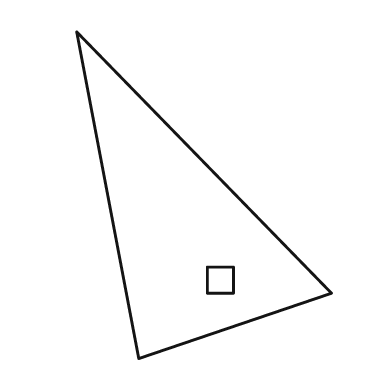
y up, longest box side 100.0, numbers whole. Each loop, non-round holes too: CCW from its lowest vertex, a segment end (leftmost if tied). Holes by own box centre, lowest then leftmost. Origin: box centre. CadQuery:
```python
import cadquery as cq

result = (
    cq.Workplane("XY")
    .moveTo(-20.0, -50.0)
    .lineTo(39.0, -30.0)
    .lineTo(-39.0, 50.0)
    .close()
    .moveTo(1.0, -30.0)
    .lineTo(9.0, -30.0)
    .lineTo(9.0, -22.0)
    .lineTo(1.0, -22.0)
    .close()
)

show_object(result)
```